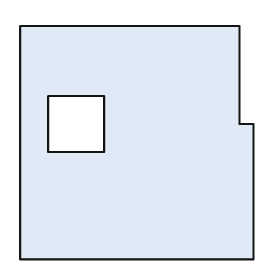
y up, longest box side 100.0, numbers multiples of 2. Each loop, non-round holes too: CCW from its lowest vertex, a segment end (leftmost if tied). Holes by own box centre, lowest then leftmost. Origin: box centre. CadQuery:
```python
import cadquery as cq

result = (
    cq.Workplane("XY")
    .moveTo(-50.0, -50.0)
    .lineTo(50.0, -50.0)
    .lineTo(50.0, 8.0)
    .lineTo(44.0, 8.0)
    .lineTo(44.0, 50.0)
    .lineTo(-50.0, 50.0)
    .close()
    .moveTo(-38.0, -4.0)
    .lineTo(-14.0, -4.0)
    .lineTo(-14.0, 20.0)
    .lineTo(-38.0, 20.0)
    .close()
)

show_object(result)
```